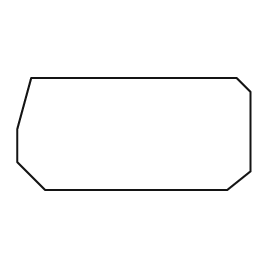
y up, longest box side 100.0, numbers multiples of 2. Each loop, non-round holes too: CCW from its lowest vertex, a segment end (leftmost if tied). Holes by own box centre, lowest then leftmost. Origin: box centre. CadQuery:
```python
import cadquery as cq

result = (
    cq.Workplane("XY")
    .moveTo(-38.0, -24.0)
    .lineTo(40.0, -24.0)
    .lineTo(50.0, -16.0)
    .lineTo(50.0, 18.0)
    .lineTo(44.0, 24.0)
    .lineTo(-44.0, 24.0)
    .lineTo(-50.0, 2.0)
    .lineTo(-50.0, -12.0)
    .close()
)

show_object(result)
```